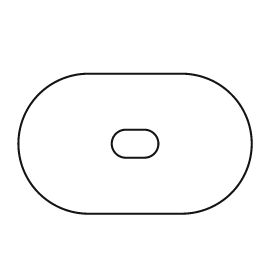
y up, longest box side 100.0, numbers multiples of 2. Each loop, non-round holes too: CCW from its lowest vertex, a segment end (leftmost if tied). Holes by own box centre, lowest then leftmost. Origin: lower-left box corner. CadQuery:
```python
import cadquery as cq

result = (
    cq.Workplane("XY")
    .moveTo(30.0, 0.0)
    .lineTo(70.0, 0.0)
    .threePointArc((100.0, 30.0), (70.0, 60.0))
    .lineTo(30.0, 60.0)
    .threePointArc((0.0, 30.0), (30.0, 0.0))
    .close()
    .moveTo(46.0, 24.0)
    .lineTo(54.0, 24.0)
    .threePointArc((60.0, 30.0), (54.0, 36.0))
    .lineTo(46.0, 36.0)
    .threePointArc((40.0, 30.0), (46.0, 24.0))
    .close()
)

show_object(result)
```